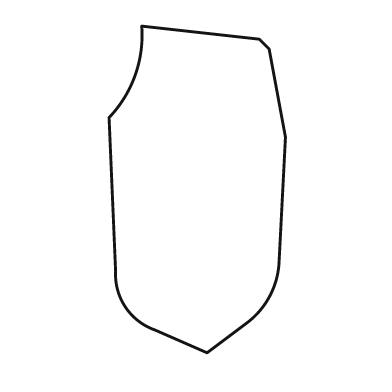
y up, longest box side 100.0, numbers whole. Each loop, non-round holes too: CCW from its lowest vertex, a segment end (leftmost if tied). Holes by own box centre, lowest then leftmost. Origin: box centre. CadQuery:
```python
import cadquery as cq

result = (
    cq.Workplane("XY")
    .moveTo(3.0, -50.0)
    .lineTo(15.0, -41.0)
    .threePointArc((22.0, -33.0), (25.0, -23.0))
    .lineTo(27.0, 16.0)
    .lineTo(22.0, 43.0)
    .lineTo(19.0, 46.0)
    .lineTo(-17.0, 50.0)
    .threePointArc((-19.0, 35.0), (-27.0, 22.0))
    .lineTo(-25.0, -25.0)
    .threePointArc((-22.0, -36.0), (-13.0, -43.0))
    .close()
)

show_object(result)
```